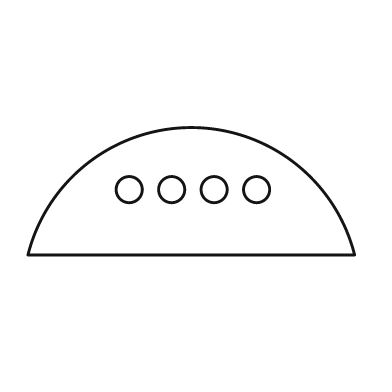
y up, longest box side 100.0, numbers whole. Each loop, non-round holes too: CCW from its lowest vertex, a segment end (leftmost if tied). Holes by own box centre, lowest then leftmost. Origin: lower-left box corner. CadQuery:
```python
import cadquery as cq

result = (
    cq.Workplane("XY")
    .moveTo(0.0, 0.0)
    .lineTo(100.0, 0.0)
    .threePointArc((50.0, 39.0), (0.0, 0.0))
    .close()
    .moveTo(31.0, 20.0)
    .circle(4.0)
    .moveTo(44.0, 20.0)
    .circle(4.0)
    .moveTo(57.0, 20.0)
    .circle(4.0)
    .moveTo(70.0, 20.0)
    .circle(4.0)
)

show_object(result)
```